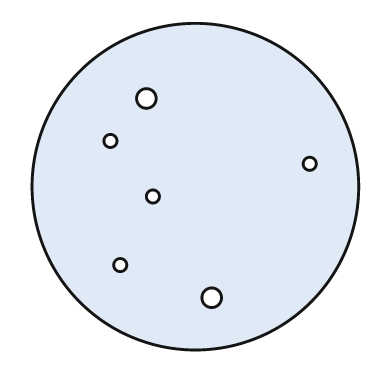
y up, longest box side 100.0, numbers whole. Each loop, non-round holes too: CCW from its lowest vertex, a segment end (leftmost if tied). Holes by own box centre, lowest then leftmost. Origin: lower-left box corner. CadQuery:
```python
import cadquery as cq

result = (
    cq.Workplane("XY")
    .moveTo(50.0, 50.0)
    .circle(50.0)
    .moveTo(55.0, 16.0)
    .circle(3.0)
    .moveTo(27.0, 26.0)
    .circle(2.0)
    .moveTo(37.0, 47.0)
    .circle(2.0)
    .moveTo(85.0, 57.0)
    .circle(2.0)
    .moveTo(24.0, 64.0)
    .circle(2.0)
    .moveTo(35.0, 77.0)
    .circle(3.0)
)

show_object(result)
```